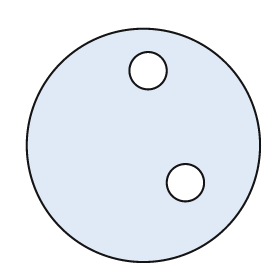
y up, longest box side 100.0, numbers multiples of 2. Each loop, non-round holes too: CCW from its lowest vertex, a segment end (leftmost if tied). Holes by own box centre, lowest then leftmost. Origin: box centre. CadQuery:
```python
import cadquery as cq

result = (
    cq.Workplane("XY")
    .moveTo(0.0, 0.0)
    .circle(50.0)
    .moveTo(18.0, -16.0)
    .circle(8.0)
    .moveTo(2.0, 32.0)
    .circle(8.0)
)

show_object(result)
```